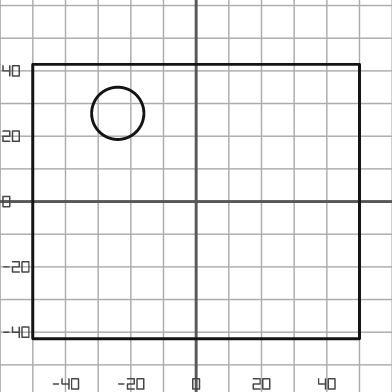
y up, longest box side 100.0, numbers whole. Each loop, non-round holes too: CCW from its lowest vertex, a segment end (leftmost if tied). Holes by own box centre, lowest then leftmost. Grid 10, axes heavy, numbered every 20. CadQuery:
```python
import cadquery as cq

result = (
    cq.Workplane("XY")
    .moveTo(-50.0, -42.0)
    .lineTo(50.0, -42.0)
    .lineTo(50.0, 42.0)
    .lineTo(-50.0, 42.0)
    .close()
    .moveTo(-24.0, 27.0)
    .circle(8.0)
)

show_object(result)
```